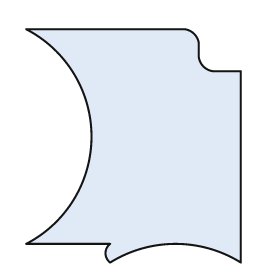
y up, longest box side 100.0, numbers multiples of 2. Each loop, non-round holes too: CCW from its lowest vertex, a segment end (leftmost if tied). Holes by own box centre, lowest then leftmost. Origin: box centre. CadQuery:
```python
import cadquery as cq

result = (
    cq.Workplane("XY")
    .moveTo(-10.0, -50.0)
    .threePointArc((18.0, -42.0), (46.0, -50.0))
    .lineTo(46.0, 32.0)
    .lineTo(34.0, 32.0)
    .threePointArc((30.0, 34.0), (28.0, 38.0))
    .lineTo(28.0, 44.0)
    .threePointArc((26.0, 48.0), (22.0, 50.0))
    .lineTo(-46.0, 50.0)
    .threePointArc((-18.0, 4.0), (-46.0, -42.0))
    .lineTo(-10.0, -42.0)
    .threePointArc((-12.0, -46.0), (-10.0, -50.0))
    .close()
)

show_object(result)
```